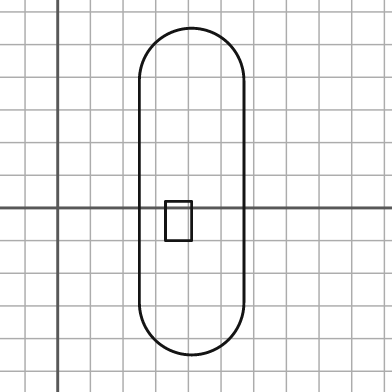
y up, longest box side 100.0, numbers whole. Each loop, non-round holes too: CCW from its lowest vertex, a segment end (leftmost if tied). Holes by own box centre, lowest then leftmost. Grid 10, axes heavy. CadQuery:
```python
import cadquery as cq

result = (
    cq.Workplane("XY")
    .moveTo(25.0, -29.0)
    .threePointArc((41.0, -45.0), (57.0, -29.0))
    .lineTo(57.0, 39.0)
    .threePointArc((41.0, 55.0), (25.0, 39.0))
    .close()
    .moveTo(33.0, -10.0)
    .lineTo(41.0, -10.0)
    .lineTo(41.0, 2.0)
    .lineTo(33.0, 2.0)
    .close()
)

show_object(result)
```